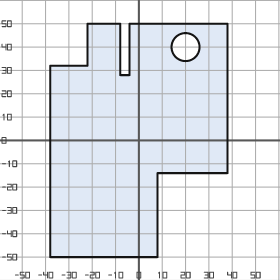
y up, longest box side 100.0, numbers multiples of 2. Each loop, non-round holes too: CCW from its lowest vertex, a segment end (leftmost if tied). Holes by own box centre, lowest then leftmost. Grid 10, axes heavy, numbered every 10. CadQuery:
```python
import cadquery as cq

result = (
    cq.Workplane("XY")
    .moveTo(-38.0, -50.0)
    .lineTo(8.0, -50.0)
    .lineTo(8.0, -14.0)
    .lineTo(38.0, -14.0)
    .lineTo(38.0, 50.0)
    .lineTo(-4.0, 50.0)
    .lineTo(-4.0, 28.0)
    .lineTo(-8.0, 28.0)
    .lineTo(-8.0, 50.0)
    .lineTo(-22.0, 50.0)
    .lineTo(-22.0, 32.0)
    .lineTo(-38.0, 32.0)
    .close()
    .moveTo(20.0, 40.0)
    .circle(6.0)
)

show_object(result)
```